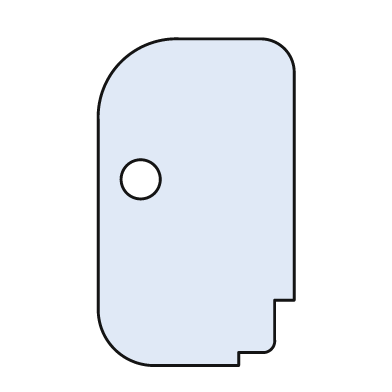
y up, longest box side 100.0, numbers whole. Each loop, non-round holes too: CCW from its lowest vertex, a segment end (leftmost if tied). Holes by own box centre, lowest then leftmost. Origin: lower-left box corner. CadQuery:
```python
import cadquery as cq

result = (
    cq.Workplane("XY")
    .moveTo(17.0, 0.0)
    .lineTo(43.0, 0.0)
    .lineTo(43.0, 4.0)
    .lineTo(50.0, 4.0)
    .threePointArc((53.0, 5.0), (54.0, 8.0))
    .lineTo(54.0, 20.0)
    .lineTo(60.0, 20.0)
    .lineTo(60.0, 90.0)
    .threePointArc((57.0, 97.0), (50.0, 100.0))
    .lineTo(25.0, 100.0)
    .threePointArc((7.0, 93.0), (0.0, 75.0))
    .lineTo(0.0, 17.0)
    .threePointArc((5.0, 5.0), (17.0, 0.0))
    .close()
    .moveTo(13.0, 57.0)
    .circle(6.0)
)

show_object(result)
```